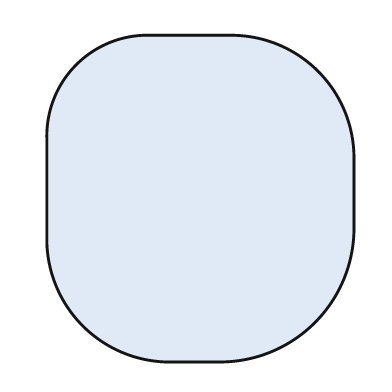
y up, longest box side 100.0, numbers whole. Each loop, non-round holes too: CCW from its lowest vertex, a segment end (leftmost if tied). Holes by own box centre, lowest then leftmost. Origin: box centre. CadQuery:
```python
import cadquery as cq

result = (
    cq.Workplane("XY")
    .moveTo(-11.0, -50.0)
    .lineTo(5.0, -50.0)
    .threePointArc((35.0, -38.0), (47.0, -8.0))
    .lineTo(47.0, 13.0)
    .threePointArc((36.0, 39.0), (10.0, 50.0))
    .lineTo(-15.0, 50.0)
    .threePointArc((-38.0, 41.0), (-47.0, 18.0))
    .lineTo(-47.0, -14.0)
    .threePointArc((-36.0, -39.0), (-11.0, -50.0))
    .close()
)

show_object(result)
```